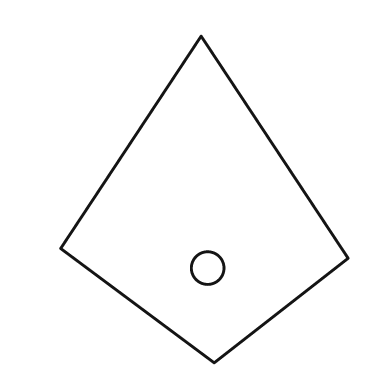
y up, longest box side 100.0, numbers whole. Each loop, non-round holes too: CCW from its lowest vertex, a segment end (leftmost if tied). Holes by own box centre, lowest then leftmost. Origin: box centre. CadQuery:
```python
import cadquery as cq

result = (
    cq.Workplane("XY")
    .moveTo(3.0, -50.0)
    .lineTo(44.0, -18.0)
    .lineTo(-1.0, 50.0)
    .lineTo(-44.0, -15.0)
    .close()
    .moveTo(1.0, -21.0)
    .circle(5.0)
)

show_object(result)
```